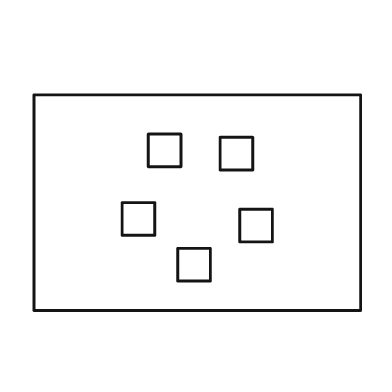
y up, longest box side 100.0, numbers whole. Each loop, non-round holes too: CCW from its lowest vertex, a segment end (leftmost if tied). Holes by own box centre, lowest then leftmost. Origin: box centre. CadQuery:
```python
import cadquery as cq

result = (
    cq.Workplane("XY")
    .moveTo(-50.0, -33.0)
    .lineTo(50.0, -33.0)
    .lineTo(50.0, 33.0)
    .lineTo(-50.0, 33.0)
    .close()
    .moveTo(-6.0, -24.0)
    .lineTo(4.0, -24.0)
    .lineTo(4.0, -14.0)
    .lineTo(-6.0, -14.0)
    .close()
    .moveTo(13.0, -12.0)
    .lineTo(23.0, -12.0)
    .lineTo(23.0, -2.0)
    .lineTo(13.0, -2.0)
    .close()
    .moveTo(-23.0, -10.0)
    .lineTo(-13.0, -10.0)
    .lineTo(-13.0, 0.0)
    .lineTo(-23.0, 0.0)
    .close()
    .moveTo(7.0, 10.0)
    .lineTo(17.0, 10.0)
    .lineTo(17.0, 20.0)
    .lineTo(7.0, 20.0)
    .close()
    .moveTo(-15.0, 11.0)
    .lineTo(-5.0, 11.0)
    .lineTo(-5.0, 21.0)
    .lineTo(-15.0, 21.0)
    .close()
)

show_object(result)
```